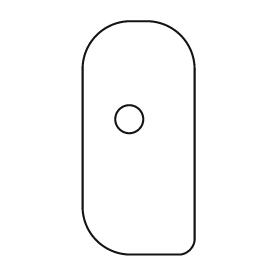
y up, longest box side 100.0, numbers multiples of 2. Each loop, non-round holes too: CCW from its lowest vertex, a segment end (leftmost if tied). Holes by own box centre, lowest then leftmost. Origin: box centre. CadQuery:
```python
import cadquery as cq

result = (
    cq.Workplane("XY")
    .moveTo(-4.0, -50.0)
    .lineTo(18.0, -50.0)
    .threePointArc((22.0, -48.0), (24.0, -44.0))
    .lineTo(24.0, 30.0)
    .threePointArc((18.0, 44.0), (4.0, 50.0))
    .lineTo(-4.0, 50.0)
    .threePointArc((-18.0, 44.0), (-24.0, 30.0))
    .lineTo(-24.0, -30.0)
    .threePointArc((-18.0, -44.0), (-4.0, -50.0))
    .close()
    .moveTo(-4.0, 8.0)
    .circle(6.0)
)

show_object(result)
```